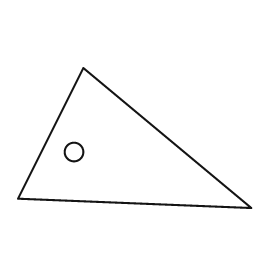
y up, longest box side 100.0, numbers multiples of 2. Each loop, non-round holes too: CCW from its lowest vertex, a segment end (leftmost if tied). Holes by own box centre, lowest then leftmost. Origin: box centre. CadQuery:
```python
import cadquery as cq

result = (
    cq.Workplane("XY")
    .moveTo(50.0, -30.0)
    .lineTo(-22.0, 30.0)
    .lineTo(-50.0, -26.0)
    .close()
    .moveTo(-26.0, -6.0)
    .circle(4.0)
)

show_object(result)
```